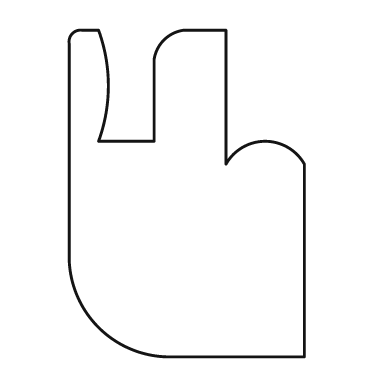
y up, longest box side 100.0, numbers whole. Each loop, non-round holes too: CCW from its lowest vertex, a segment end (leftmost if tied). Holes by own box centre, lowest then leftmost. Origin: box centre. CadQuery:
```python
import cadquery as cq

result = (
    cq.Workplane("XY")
    .moveTo(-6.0, -50.0)
    .lineTo(36.0, -50.0)
    .lineTo(36.0, 9.0)
    .threePointArc((24.0, 16.0), (12.0, 9.0))
    .lineTo(12.0, 50.0)
    .lineTo(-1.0, 50.0)
    .threePointArc((-7.0, 47.0), (-10.0, 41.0))
    .lineTo(-10.0, 16.0)
    .lineTo(-27.0, 16.0)
    .threePointArc((-24.0, 33.0), (-27.0, 50.0))
    .lineTo(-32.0, 50.0)
    .threePointArc((-35.0, 49.0), (-36.0, 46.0))
    .lineTo(-36.0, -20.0)
    .threePointArc((-27.0, -41.0), (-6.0, -50.0))
    .close()
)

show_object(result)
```